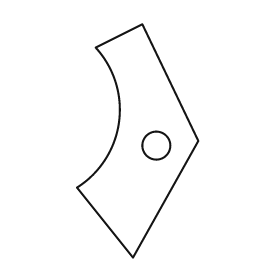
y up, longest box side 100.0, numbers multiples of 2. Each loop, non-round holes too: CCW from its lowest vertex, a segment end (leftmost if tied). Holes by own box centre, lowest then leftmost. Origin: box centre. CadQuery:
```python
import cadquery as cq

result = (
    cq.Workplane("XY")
    .moveTo(-2.0, -50.0)
    .lineTo(26.0, 0.0)
    .lineTo(2.0, 50.0)
    .lineTo(-18.0, 40.0)
    .threePointArc((-8.0, 8.0), (-26.0, -20.0))
    .close()
    .moveTo(8.0, -2.0)
    .circle(6.0)
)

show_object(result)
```